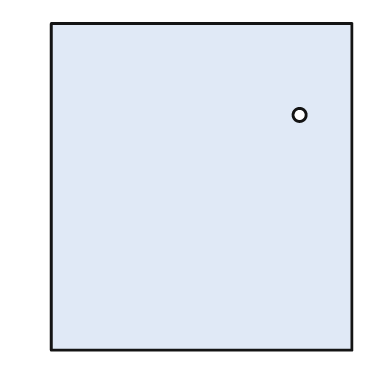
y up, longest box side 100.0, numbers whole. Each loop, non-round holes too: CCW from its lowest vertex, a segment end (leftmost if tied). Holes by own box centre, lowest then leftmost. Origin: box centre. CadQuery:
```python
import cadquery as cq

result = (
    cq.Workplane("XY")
    .moveTo(-46.0, -50.0)
    .lineTo(46.0, -50.0)
    .lineTo(46.0, 50.0)
    .lineTo(-46.0, 50.0)
    .close()
    .moveTo(30.0, 22.0)
    .circle(2.0)
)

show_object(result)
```